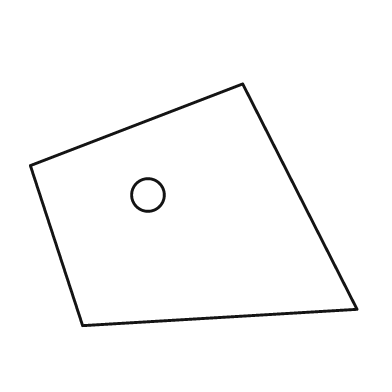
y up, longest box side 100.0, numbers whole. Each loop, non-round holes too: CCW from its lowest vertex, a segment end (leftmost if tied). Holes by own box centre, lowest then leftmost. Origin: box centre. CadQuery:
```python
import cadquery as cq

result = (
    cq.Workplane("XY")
    .moveTo(-34.0, -37.0)
    .lineTo(50.0, -32.0)
    .lineTo(15.0, 37.0)
    .lineTo(-50.0, 12.0)
    .close()
    .moveTo(-14.0, 3.0)
    .circle(5.0)
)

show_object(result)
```